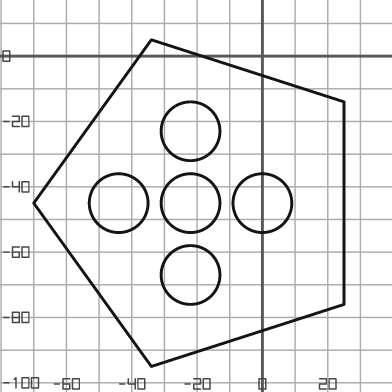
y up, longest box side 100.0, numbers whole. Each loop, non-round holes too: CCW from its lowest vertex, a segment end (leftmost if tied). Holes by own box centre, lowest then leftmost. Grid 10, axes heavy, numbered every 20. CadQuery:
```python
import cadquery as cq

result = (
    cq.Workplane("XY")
    .moveTo(-34.0, -95.0)
    .lineTo(25.0, -76.0)
    .lineTo(25.0, -14.0)
    .lineTo(-34.0, 5.0)
    .lineTo(-70.0, -45.0)
    .close()
    .moveTo(-22.0, -67.0)
    .circle(9.0)
    .moveTo(-44.0, -45.0)
    .circle(9.0)
    .moveTo(-22.0, -45.0)
    .circle(9.0)
    .moveTo(0.0, -45.0)
    .circle(9.0)
    .moveTo(-22.0, -23.0)
    .circle(9.0)
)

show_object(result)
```